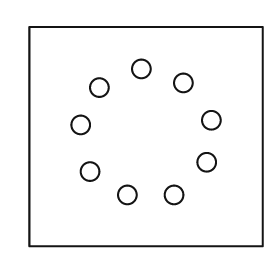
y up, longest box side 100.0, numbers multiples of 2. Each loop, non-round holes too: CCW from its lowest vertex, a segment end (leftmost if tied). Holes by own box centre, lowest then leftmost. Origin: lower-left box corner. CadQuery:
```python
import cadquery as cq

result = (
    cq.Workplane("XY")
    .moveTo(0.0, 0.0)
    .lineTo(100.0, 0.0)
    .lineTo(100.0, 94.0)
    .lineTo(0.0, 94.0)
    .close()
    .moveTo(42.0, 22.0)
    .circle(4.0)
    .moveTo(62.0, 22.0)
    .circle(4.0)
    .moveTo(26.0, 32.0)
    .circle(4.0)
    .moveTo(76.0, 36.0)
    .circle(4.0)
    .moveTo(22.0, 52.0)
    .circle(4.0)
    .moveTo(78.0, 54.0)
    .circle(4.0)
    .moveTo(30.0, 68.0)
    .circle(4.0)
    .moveTo(66.0, 70.0)
    .circle(4.0)
    .moveTo(48.0, 76.0)
    .circle(4.0)
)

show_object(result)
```